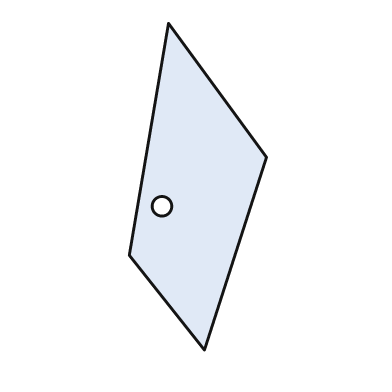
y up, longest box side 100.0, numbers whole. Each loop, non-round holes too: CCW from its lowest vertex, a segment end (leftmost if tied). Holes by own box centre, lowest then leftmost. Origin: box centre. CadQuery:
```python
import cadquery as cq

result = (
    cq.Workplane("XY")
    .moveTo(2.0, -50.0)
    .lineTo(21.0, 9.0)
    .lineTo(-9.0, 50.0)
    .lineTo(-21.0, -21.0)
    .close()
    .moveTo(-11.0, -6.0)
    .circle(3.0)
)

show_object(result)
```